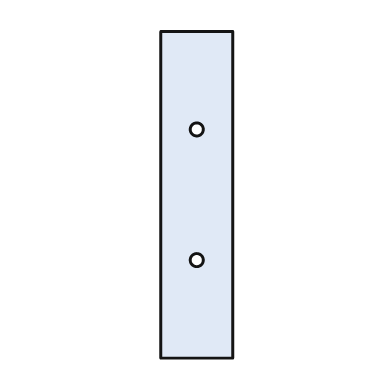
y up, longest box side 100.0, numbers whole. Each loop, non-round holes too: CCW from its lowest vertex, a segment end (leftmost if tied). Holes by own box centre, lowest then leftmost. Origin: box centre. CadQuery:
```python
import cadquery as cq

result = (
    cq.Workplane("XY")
    .moveTo(-11.0, -50.0)
    .lineTo(11.0, -50.0)
    .lineTo(11.0, 50.0)
    .lineTo(-11.0, 50.0)
    .close()
    .moveTo(0.0, -20.0)
    .circle(2.0)
    .moveTo(0.0, 20.0)
    .circle(2.0)
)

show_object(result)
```